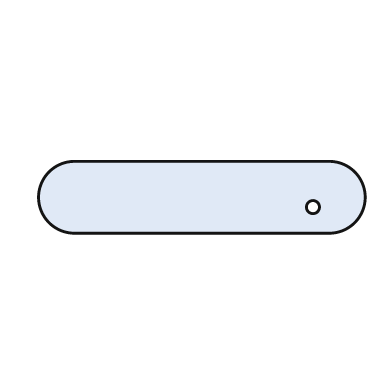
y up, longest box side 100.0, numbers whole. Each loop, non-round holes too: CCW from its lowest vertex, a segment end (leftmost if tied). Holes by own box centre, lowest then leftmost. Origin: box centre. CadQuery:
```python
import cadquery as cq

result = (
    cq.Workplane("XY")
    .moveTo(-39.0, -11.0)
    .lineTo(39.0, -11.0)
    .threePointArc((50.0, 0.0), (39.0, 11.0))
    .lineTo(-39.0, 11.0)
    .threePointArc((-50.0, 0.0), (-39.0, -11.0))
    .close()
    .moveTo(34.0, -3.0)
    .circle(2.0)
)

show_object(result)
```